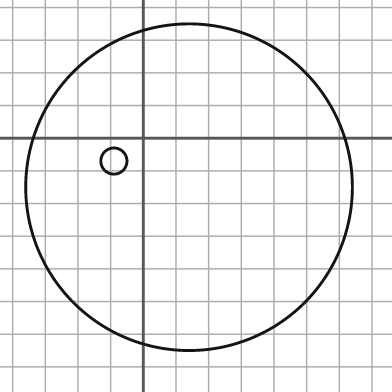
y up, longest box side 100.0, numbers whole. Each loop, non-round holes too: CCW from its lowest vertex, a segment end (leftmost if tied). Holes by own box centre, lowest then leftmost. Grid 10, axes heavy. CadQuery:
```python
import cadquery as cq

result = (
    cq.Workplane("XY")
    .moveTo(14.0, -15.0)
    .circle(50.0)
    .moveTo(-9.0, -7.0)
    .circle(4.0)
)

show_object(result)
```